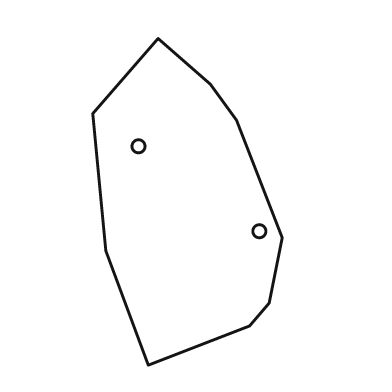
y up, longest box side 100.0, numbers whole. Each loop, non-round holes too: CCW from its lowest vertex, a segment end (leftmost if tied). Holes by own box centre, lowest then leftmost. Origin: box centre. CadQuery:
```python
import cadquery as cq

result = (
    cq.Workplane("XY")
    .moveTo(-12.0, -50.0)
    .lineTo(19.0, -38.0)
    .lineTo(25.0, -31.0)
    .lineTo(29.0, -11.0)
    .lineTo(15.0, 25.0)
    .lineTo(7.0, 36.0)
    .lineTo(-9.0, 50.0)
    .lineTo(-29.0, 27.0)
    .lineTo(-25.0, -15.0)
    .close()
    .moveTo(22.0, -9.0)
    .circle(2.0)
    .moveTo(-15.0, 17.0)
    .circle(2.0)
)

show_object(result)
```